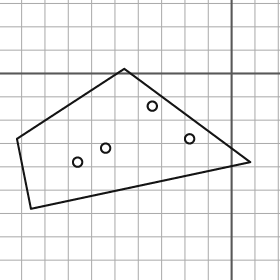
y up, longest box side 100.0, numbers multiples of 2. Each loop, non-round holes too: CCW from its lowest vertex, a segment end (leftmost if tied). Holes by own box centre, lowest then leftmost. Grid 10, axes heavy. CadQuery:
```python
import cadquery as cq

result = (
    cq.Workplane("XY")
    .moveTo(-86.0, -58.0)
    .lineTo(8.0, -38.0)
    .lineTo(-46.0, 2.0)
    .lineTo(-92.0, -28.0)
    .close()
    .moveTo(-66.0, -38.0)
    .circle(2.0)
    .moveTo(-54.0, -32.0)
    .circle(2.0)
    .moveTo(-18.0, -28.0)
    .circle(2.0)
    .moveTo(-34.0, -14.0)
    .circle(2.0)
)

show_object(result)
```